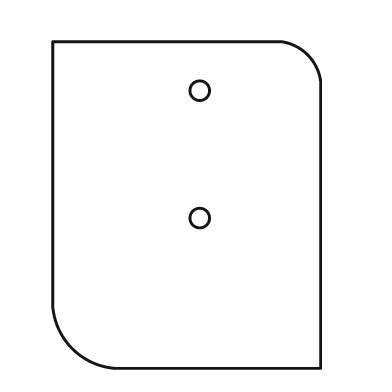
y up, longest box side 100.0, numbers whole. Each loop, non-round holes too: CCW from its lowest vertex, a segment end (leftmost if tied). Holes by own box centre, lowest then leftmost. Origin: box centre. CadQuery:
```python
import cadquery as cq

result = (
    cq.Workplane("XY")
    .moveTo(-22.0, -50.0)
    .lineTo(41.0, -50.0)
    .lineTo(41.0, 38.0)
    .threePointArc((37.0, 46.0), (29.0, 50.0))
    .lineTo(-41.0, 50.0)
    .lineTo(-41.0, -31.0)
    .threePointArc((-35.0, -44.0), (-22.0, -50.0))
    .close()
    .moveTo(4.0, -4.0)
    .circle(3.0)
    .moveTo(4.0, 35.0)
    .circle(3.0)
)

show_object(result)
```